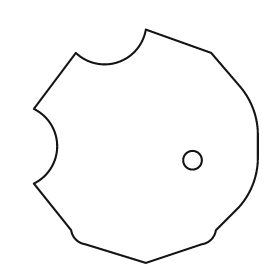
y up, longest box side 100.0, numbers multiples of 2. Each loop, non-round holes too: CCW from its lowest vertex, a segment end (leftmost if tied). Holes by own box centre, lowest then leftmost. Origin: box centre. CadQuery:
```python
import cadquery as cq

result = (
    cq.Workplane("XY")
    .moveTo(0.0, -50.0)
    .lineTo(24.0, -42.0)
    .threePointArc((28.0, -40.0), (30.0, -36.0))
    .lineTo(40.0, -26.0)
    .threePointArc((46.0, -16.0), (48.0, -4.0))
    .lineTo(48.0, 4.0)
    .threePointArc((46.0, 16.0), (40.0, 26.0))
    .lineTo(28.0, 40.0)
    .lineTo(0.0, 50.0)
    .threePointArc((-12.0, 36.0), (-30.0, 40.0))
    .lineTo(-48.0, 16.0)
    .threePointArc((-38.0, 0.0), (-48.0, -16.0))
    .lineTo(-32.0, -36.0)
    .threePointArc((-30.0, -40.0), (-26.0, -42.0))
    .close()
    .moveTo(20.0, -6.0)
    .circle(4.0)
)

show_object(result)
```